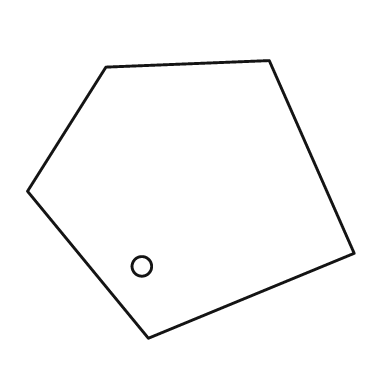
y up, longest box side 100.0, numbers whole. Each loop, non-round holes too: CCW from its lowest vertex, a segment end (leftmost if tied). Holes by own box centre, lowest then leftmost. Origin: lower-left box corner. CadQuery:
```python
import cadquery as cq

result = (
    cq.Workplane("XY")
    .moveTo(37.0, 0.0)
    .lineTo(100.0, 26.0)
    .lineTo(74.0, 85.0)
    .lineTo(24.0, 83.0)
    .lineTo(0.0, 45.0)
    .close()
    .moveTo(35.0, 22.0)
    .circle(3.0)
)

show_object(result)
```